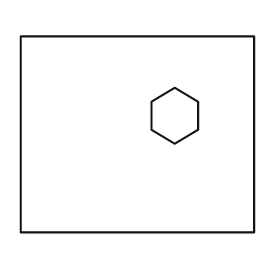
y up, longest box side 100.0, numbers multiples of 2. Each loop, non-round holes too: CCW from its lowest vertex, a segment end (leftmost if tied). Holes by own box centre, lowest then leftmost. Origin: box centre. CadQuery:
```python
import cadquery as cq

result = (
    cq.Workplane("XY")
    .moveTo(-50.0, -42.0)
    .lineTo(50.0, -42.0)
    .lineTo(50.0, 42.0)
    .lineTo(-50.0, 42.0)
    .close()
    .moveTo(16.0, -4.0)
    .lineTo(26.0, 2.0)
    .lineTo(26.0, 14.0)
    .lineTo(16.0, 20.0)
    .lineTo(6.0, 14.0)
    .lineTo(6.0, 2.0)
    .close()
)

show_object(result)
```